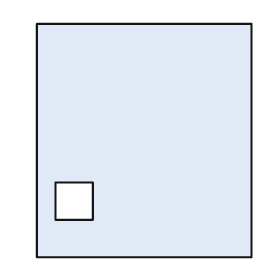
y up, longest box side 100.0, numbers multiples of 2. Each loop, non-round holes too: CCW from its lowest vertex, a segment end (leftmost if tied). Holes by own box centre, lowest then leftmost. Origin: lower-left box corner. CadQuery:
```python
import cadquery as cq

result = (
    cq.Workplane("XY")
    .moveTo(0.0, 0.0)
    .lineTo(92.0, 0.0)
    .lineTo(92.0, 100.0)
    .lineTo(0.0, 100.0)
    .close()
    .moveTo(8.0, 16.0)
    .lineTo(24.0, 16.0)
    .lineTo(24.0, 32.0)
    .lineTo(8.0, 32.0)
    .close()
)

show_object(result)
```